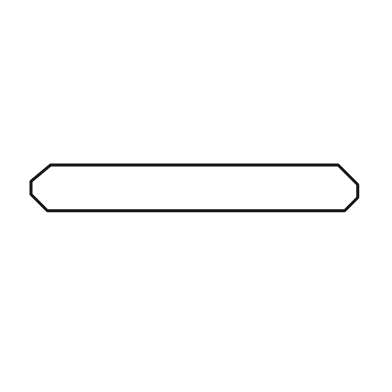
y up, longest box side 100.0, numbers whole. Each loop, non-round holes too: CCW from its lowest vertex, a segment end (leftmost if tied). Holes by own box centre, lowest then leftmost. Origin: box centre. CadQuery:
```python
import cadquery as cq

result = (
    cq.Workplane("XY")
    .moveTo(-45.0, -7.0)
    .lineTo(46.0, -7.0)
    .lineTo(50.0, -3.0)
    .lineTo(50.0, 1.0)
    .lineTo(44.0, 7.0)
    .lineTo(-44.0, 7.0)
    .lineTo(-50.0, 2.0)
    .lineTo(-50.0, -2.0)
    .close()
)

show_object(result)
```